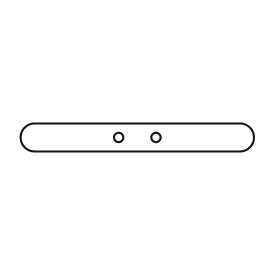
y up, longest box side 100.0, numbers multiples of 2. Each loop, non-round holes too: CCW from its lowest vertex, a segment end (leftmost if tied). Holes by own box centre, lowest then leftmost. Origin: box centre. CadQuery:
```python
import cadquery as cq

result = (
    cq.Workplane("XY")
    .moveTo(-44.0, -6.0)
    .lineTo(44.0, -6.0)
    .threePointArc((50.0, 0.0), (44.0, 6.0))
    .lineTo(-44.0, 6.0)
    .threePointArc((-50.0, 0.0), (-44.0, -6.0))
    .close()
    .moveTo(-8.0, 0.0)
    .circle(2.0)
    .moveTo(8.0, 0.0)
    .circle(2.0)
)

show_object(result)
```